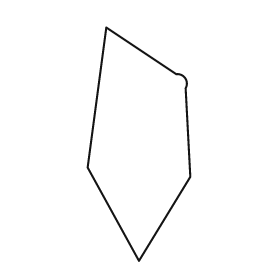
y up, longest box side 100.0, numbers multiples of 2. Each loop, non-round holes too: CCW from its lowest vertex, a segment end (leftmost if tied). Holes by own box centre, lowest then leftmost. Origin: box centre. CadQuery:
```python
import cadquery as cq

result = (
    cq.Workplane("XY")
    .moveTo(0.0, -50.0)
    .lineTo(22.0, -14.0)
    .lineTo(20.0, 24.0)
    .threePointArc((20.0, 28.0), (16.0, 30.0))
    .lineTo(-14.0, 50.0)
    .lineTo(-22.0, -10.0)
    .close()
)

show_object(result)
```